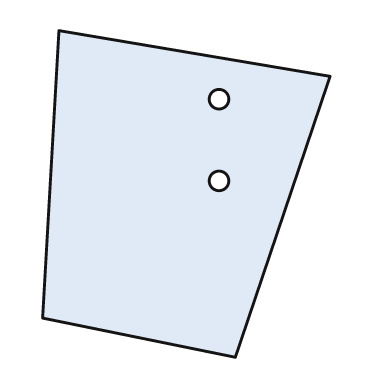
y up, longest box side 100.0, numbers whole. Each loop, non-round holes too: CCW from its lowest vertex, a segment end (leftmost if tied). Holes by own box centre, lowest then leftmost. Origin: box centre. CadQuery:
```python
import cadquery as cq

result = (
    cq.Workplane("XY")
    .moveTo(15.0, -50.0)
    .lineTo(44.0, 36.0)
    .lineTo(-39.0, 50.0)
    .lineTo(-44.0, -38.0)
    .close()
    .moveTo(10.0, 4.0)
    .circle(3.0)
    .moveTo(10.0, 29.0)
    .circle(3.0)
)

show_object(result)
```